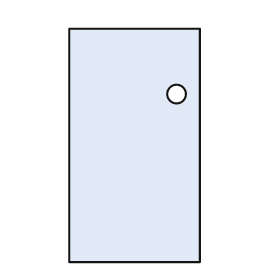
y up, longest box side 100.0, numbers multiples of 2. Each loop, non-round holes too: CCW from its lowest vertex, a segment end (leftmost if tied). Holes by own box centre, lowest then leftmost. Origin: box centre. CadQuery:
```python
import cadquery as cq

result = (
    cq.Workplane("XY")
    .moveTo(-28.0, -50.0)
    .lineTo(28.0, -50.0)
    .lineTo(28.0, 50.0)
    .lineTo(-28.0, 50.0)
    .close()
    .moveTo(18.0, 22.0)
    .circle(4.0)
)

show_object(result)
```